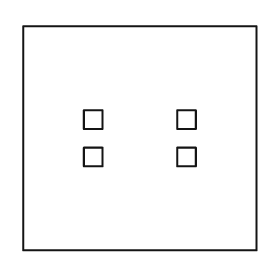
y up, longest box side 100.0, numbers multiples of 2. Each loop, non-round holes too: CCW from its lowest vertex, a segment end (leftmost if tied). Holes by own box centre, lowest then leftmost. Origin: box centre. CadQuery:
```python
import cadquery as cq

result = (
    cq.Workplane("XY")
    .moveTo(-50.0, -48.0)
    .lineTo(50.0, -48.0)
    .lineTo(50.0, 48.0)
    .lineTo(-50.0, 48.0)
    .close()
    .moveTo(-24.0, -12.0)
    .lineTo(-16.0, -12.0)
    .lineTo(-16.0, -4.0)
    .lineTo(-24.0, -4.0)
    .close()
    .moveTo(16.0, -12.0)
    .lineTo(24.0, -12.0)
    .lineTo(24.0, -4.0)
    .lineTo(16.0, -4.0)
    .close()
    .moveTo(-24.0, 4.0)
    .lineTo(-16.0, 4.0)
    .lineTo(-16.0, 12.0)
    .lineTo(-24.0, 12.0)
    .close()
    .moveTo(16.0, 4.0)
    .lineTo(24.0, 4.0)
    .lineTo(24.0, 12.0)
    .lineTo(16.0, 12.0)
    .close()
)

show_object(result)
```